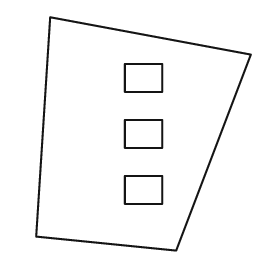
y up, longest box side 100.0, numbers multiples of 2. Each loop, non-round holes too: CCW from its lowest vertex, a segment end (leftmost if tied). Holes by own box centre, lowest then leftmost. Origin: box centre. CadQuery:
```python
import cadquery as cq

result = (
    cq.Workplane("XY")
    .moveTo(14.0, -50.0)
    .lineTo(46.0, 34.0)
    .lineTo(-40.0, 50.0)
    .lineTo(-46.0, -44.0)
    .close()
    .moveTo(-8.0, -30.0)
    .lineTo(8.0, -30.0)
    .lineTo(8.0, -18.0)
    .lineTo(-8.0, -18.0)
    .close()
    .moveTo(-8.0, -6.0)
    .lineTo(8.0, -6.0)
    .lineTo(8.0, 6.0)
    .lineTo(-8.0, 6.0)
    .close()
    .moveTo(-8.0, 18.0)
    .lineTo(8.0, 18.0)
    .lineTo(8.0, 30.0)
    .lineTo(-8.0, 30.0)
    .close()
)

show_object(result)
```